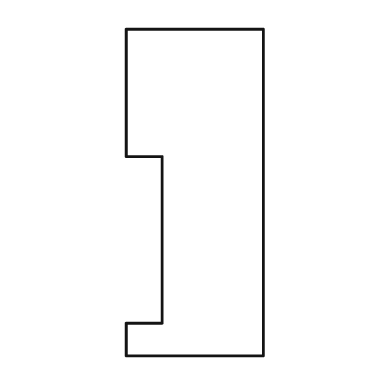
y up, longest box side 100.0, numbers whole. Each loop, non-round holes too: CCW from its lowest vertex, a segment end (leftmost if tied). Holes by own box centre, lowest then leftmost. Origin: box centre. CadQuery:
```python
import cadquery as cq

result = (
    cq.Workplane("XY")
    .moveTo(-21.0, -50.0)
    .lineTo(21.0, -50.0)
    .lineTo(21.0, 50.0)
    .lineTo(-21.0, 50.0)
    .lineTo(-21.0, 11.0)
    .lineTo(-10.0, 11.0)
    .lineTo(-10.0, -40.0)
    .lineTo(-21.0, -40.0)
    .close()
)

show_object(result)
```